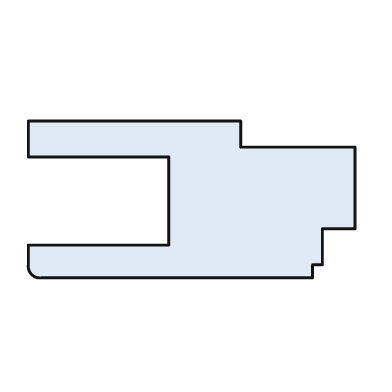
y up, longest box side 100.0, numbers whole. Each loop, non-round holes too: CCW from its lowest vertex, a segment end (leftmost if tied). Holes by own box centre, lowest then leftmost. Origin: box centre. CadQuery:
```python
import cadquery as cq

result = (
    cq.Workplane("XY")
    .moveTo(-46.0, -24.0)
    .lineTo(37.0, -24.0)
    .lineTo(37.0, -20.0)
    .lineTo(40.0, -20.0)
    .lineTo(40.0, -9.0)
    .lineTo(50.0, -9.0)
    .lineTo(50.0, 16.0)
    .lineTo(15.0, 16.0)
    .lineTo(15.0, 24.0)
    .lineTo(-50.0, 24.0)
    .lineTo(-50.0, 13.0)
    .lineTo(-7.0, 13.0)
    .lineTo(-7.0, -14.0)
    .lineTo(-50.0, -14.0)
    .lineTo(-50.0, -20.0)
    .threePointArc((-49.0, -23.0), (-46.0, -24.0))
    .close()
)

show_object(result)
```